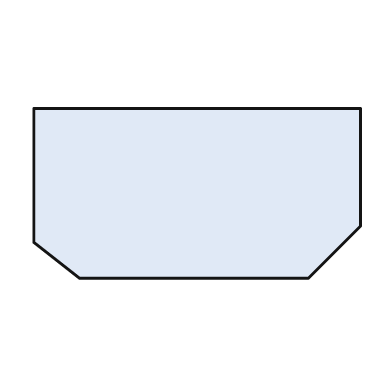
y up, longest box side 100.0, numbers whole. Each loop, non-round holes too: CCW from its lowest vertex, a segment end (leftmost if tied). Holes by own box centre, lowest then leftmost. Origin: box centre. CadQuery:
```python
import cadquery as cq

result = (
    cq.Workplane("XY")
    .moveTo(-36.0, -26.0)
    .lineTo(34.0, -26.0)
    .lineTo(50.0, -10.0)
    .lineTo(50.0, 26.0)
    .lineTo(-50.0, 26.0)
    .lineTo(-50.0, -15.0)
    .close()
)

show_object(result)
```